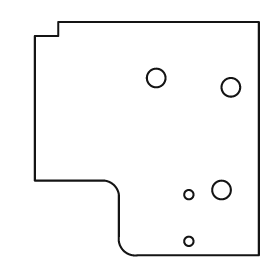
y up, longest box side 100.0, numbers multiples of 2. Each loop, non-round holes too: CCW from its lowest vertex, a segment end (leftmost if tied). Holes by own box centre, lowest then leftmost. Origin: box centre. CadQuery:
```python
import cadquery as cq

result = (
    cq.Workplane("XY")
    .moveTo(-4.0, -50.0)
    .lineTo(48.0, -50.0)
    .lineTo(48.0, 50.0)
    .lineTo(-38.0, 50.0)
    .lineTo(-38.0, 44.0)
    .lineTo(-48.0, 44.0)
    .lineTo(-48.0, -18.0)
    .lineTo(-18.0, -18.0)
    .threePointArc((-14.0, -20.0), (-12.0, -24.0))
    .lineTo(-12.0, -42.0)
    .threePointArc((-10.0, -48.0), (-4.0, -50.0))
    .close()
    .moveTo(18.0, -44.0)
    .circle(2.0)
    .moveTo(18.0, -24.0)
    .circle(2.0)
    .moveTo(32.0, -22.0)
    .circle(4.0)
    .moveTo(36.0, 22.0)
    .circle(4.0)
    .moveTo(4.0, 26.0)
    .circle(4.0)
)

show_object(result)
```